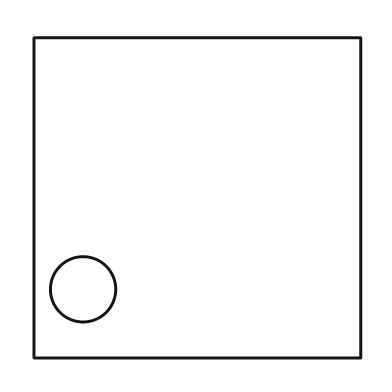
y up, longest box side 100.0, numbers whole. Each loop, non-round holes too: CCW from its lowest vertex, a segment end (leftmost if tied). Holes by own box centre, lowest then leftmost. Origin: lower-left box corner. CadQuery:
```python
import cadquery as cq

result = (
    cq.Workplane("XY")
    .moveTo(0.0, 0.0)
    .lineTo(100.0, 0.0)
    .lineTo(100.0, 98.0)
    .lineTo(0.0, 98.0)
    .close()
    .moveTo(15.0, 21.0)
    .circle(10.0)
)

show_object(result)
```